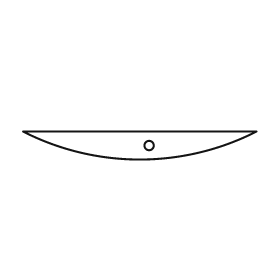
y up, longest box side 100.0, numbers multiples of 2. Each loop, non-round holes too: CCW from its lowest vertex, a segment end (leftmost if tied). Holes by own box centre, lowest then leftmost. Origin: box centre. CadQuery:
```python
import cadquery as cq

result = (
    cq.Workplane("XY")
    .moveTo(-50.0, 6.0)
    .threePointArc((0.0, -6.0), (50.0, 6.0))
    .close()
    .moveTo(4.0, 0.0)
    .circle(2.0)
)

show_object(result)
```